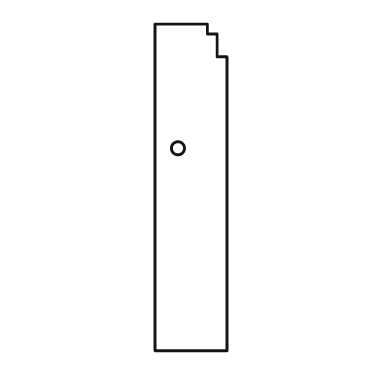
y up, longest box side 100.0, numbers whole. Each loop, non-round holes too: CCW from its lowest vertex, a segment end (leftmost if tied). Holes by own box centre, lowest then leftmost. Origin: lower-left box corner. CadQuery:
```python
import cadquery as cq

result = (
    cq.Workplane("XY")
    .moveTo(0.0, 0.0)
    .lineTo(22.0, 0.0)
    .lineTo(22.0, 90.0)
    .lineTo(19.0, 90.0)
    .lineTo(19.0, 97.0)
    .lineTo(16.0, 97.0)
    .lineTo(16.0, 100.0)
    .lineTo(0.0, 100.0)
    .close()
    .moveTo(7.0, 62.0)
    .circle(2.0)
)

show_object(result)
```